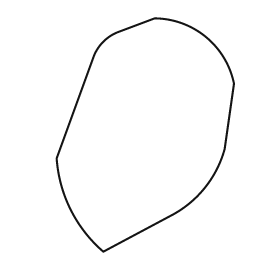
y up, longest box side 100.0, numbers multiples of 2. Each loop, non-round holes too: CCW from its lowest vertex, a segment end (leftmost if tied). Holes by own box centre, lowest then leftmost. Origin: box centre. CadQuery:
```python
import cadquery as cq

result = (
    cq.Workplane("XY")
    .moveTo(-18.0, -50.0)
    .lineTo(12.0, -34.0)
    .threePointArc((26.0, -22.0), (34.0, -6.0))
    .lineTo(38.0, 22.0)
    .threePointArc((26.0, 42.0), (4.0, 50.0))
    .lineTo(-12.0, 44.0)
    .threePointArc((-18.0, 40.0), (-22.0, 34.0))
    .lineTo(-38.0, -10.0)
    .threePointArc((-32.0, -32.0), (-18.0, -50.0))
    .close()
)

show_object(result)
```